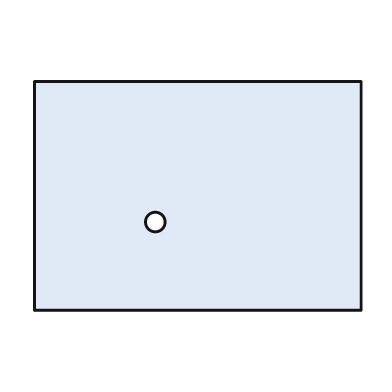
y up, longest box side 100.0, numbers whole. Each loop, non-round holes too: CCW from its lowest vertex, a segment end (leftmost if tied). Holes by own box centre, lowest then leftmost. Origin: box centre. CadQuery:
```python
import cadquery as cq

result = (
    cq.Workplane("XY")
    .moveTo(-50.0, -35.0)
    .lineTo(50.0, -35.0)
    .lineTo(50.0, 35.0)
    .lineTo(-50.0, 35.0)
    .close()
    .moveTo(-13.0, -8.0)
    .circle(3.0)
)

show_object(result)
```